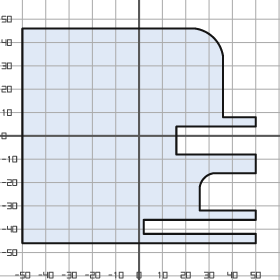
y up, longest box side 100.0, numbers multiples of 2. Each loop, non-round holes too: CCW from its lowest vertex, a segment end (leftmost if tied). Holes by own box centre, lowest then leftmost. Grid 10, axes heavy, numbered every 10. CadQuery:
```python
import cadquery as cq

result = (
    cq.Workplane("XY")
    .moveTo(-50.0, -46.0)
    .lineTo(50.0, -46.0)
    .lineTo(50.0, -42.0)
    .lineTo(2.0, -42.0)
    .lineTo(2.0, -36.0)
    .lineTo(50.0, -36.0)
    .lineTo(50.0, -32.0)
    .lineTo(26.0, -32.0)
    .lineTo(26.0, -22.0)
    .threePointArc((28.0, -18.0), (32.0, -16.0))
    .lineTo(50.0, -16.0)
    .lineTo(50.0, -8.0)
    .lineTo(16.0, -8.0)
    .lineTo(16.0, 4.0)
    .lineTo(50.0, 4.0)
    .lineTo(50.0, 8.0)
    .lineTo(36.0, 8.0)
    .lineTo(36.0, 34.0)
    .threePointArc((32.0, 42.0), (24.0, 46.0))
    .lineTo(-50.0, 46.0)
    .close()
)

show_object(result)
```